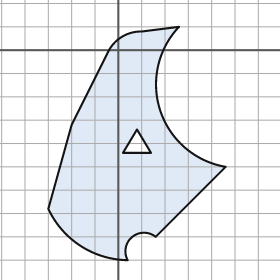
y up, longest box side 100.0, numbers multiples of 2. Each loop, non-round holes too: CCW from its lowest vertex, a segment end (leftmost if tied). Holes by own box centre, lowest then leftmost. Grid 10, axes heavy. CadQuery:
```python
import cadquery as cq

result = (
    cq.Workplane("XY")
    .moveTo(4.0, -90.0)
    .threePointArc((6.0, -80.0), (16.0, -80.0))
    .lineTo(46.0, -50.0)
    .threePointArc((18.0, -26.0), (26.0, 10.0))
    .lineTo(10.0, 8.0)
    .threePointArc((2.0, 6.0), (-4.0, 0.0))
    .lineTo(-20.0, -32.0)
    .lineTo(-30.0, -68.0)
    .threePointArc((-16.0, -84.0), (4.0, -90.0))
    .close()
    .moveTo(2.0, -44.0)
    .lineTo(14.0, -44.0)
    .lineTo(8.0, -34.0)
    .close()
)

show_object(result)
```